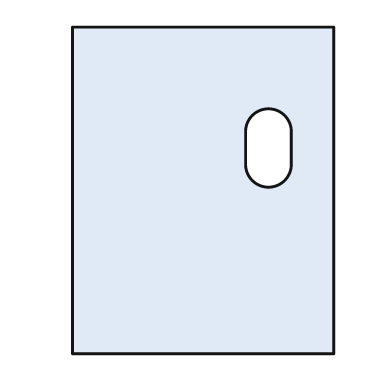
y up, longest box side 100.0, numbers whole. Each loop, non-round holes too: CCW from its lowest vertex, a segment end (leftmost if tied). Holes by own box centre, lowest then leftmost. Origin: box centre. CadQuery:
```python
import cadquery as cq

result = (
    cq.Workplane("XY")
    .moveTo(-40.0, -50.0)
    .lineTo(40.0, -50.0)
    .lineTo(40.0, 50.0)
    .lineTo(-40.0, 50.0)
    .close()
    .moveTo(13.0, 8.0)
    .threePointArc((20.0, 1.0), (27.0, 8.0))
    .lineTo(27.0, 18.0)
    .threePointArc((20.0, 25.0), (13.0, 18.0))
    .close()
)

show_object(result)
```